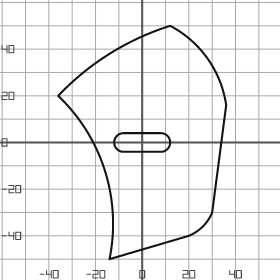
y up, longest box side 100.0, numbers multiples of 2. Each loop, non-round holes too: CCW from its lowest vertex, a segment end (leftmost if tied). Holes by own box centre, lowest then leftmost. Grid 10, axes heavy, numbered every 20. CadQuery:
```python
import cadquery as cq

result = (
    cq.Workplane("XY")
    .moveTo(-14.0, -50.0)
    .lineTo(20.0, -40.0)
    .threePointArc((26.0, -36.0), (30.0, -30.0))
    .lineTo(36.0, 16.0)
    .threePointArc((28.0, 36.0), (12.0, 50.0))
    .threePointArc((-14.0, 38.0), (-36.0, 20.0))
    .threePointArc((-16.0, -12.0), (-14.0, -50.0))
    .close()
    .moveTo(-8.0, -4.0)
    .lineTo(8.0, -4.0)
    .threePointArc((12.0, 0.0), (8.0, 4.0))
    .lineTo(-8.0, 4.0)
    .threePointArc((-12.0, 0.0), (-8.0, -4.0))
    .close()
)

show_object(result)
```